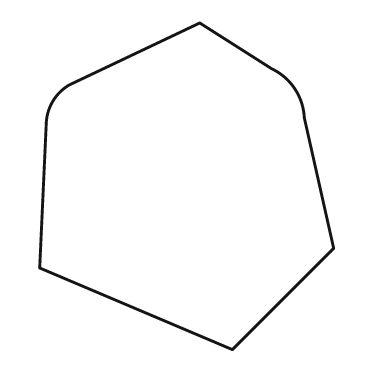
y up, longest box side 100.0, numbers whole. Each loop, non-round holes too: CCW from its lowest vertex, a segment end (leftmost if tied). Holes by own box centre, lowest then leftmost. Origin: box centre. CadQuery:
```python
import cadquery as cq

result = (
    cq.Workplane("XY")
    .moveTo(14.0, -50.0)
    .lineTo(45.0, -19.0)
    .lineTo(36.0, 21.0)
    .threePointArc((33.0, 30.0), (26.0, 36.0))
    .lineTo(4.0, 50.0)
    .lineTo(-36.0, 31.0)
    .threePointArc((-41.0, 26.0), (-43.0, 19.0))
    .lineTo(-45.0, -25.0)
    .close()
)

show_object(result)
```